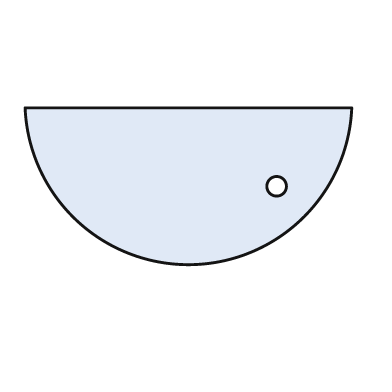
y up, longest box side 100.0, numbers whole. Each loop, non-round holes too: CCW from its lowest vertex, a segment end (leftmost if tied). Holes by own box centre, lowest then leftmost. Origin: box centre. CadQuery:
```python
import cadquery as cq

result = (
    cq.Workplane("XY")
    .moveTo(-50.0, 24.0)
    .threePointArc((0.0, -24.0), (50.0, 24.0))
    .close()
    .moveTo(27.0, 0.0)
    .circle(3.0)
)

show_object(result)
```